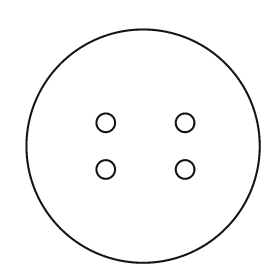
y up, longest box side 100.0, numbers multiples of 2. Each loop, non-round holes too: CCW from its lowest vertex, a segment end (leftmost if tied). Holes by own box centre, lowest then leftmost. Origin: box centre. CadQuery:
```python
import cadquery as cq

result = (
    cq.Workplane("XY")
    .moveTo(0.0, 0.0)
    .circle(50.0)
    .moveTo(-16.0, -10.0)
    .circle(4.0)
    .moveTo(18.0, -10.0)
    .circle(4.0)
    .moveTo(-16.0, 10.0)
    .circle(4.0)
    .moveTo(18.0, 10.0)
    .circle(4.0)
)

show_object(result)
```